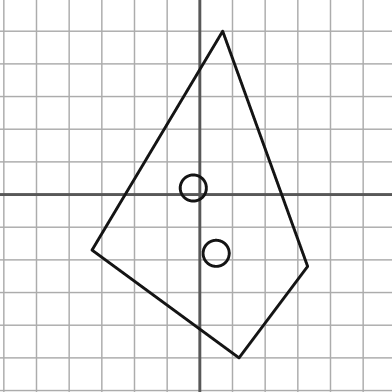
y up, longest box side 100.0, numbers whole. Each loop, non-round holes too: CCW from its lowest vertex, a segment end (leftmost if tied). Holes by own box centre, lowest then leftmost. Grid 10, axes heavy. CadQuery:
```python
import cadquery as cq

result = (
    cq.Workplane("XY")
    .moveTo(12.0, -50.0)
    .lineTo(33.0, -22.0)
    .lineTo(7.0, 50.0)
    .lineTo(-33.0, -17.0)
    .close()
    .moveTo(5.0, -18.0)
    .circle(4.0)
    .moveTo(-2.0, 2.0)
    .circle(4.0)
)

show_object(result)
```